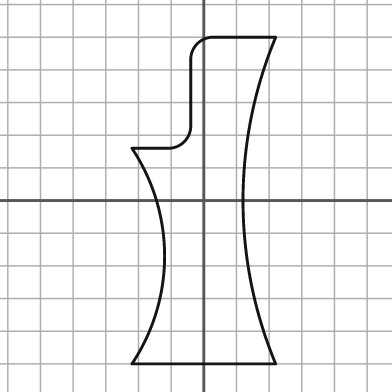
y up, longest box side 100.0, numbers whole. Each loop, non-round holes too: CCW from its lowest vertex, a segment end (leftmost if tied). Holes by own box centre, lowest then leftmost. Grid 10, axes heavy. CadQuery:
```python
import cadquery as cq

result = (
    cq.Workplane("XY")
    .moveTo(-22.0, -50.0)
    .lineTo(22.0, -50.0)
    .threePointArc((12.0, 0.0), (22.0, 50.0))
    .lineTo(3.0, 50.0)
    .threePointArc((-2.0, 48.0), (-4.0, 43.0))
    .lineTo(-4.0, 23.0)
    .threePointArc((-6.0, 18.0), (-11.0, 16.0))
    .lineTo(-22.0, 16.0)
    .threePointArc((-12.0, -17.0), (-22.0, -50.0))
    .close()
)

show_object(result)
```